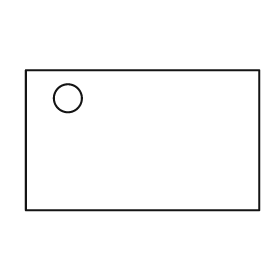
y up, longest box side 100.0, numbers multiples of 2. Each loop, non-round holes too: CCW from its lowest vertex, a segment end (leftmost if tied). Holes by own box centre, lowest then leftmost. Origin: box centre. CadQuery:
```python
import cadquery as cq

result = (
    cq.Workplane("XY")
    .moveTo(-50.0, -30.0)
    .lineTo(50.0, -30.0)
    .lineTo(50.0, 30.0)
    .lineTo(-50.0, 30.0)
    .close()
    .moveTo(-32.0, 18.0)
    .circle(6.0)
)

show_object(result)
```